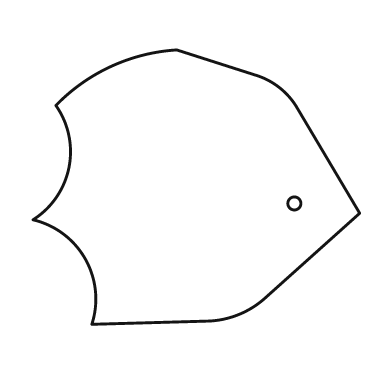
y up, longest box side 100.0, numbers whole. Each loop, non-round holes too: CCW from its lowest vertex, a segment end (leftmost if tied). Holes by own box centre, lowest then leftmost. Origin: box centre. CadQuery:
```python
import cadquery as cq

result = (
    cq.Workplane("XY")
    .moveTo(-32.0, -42.0)
    .lineTo(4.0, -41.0)
    .threePointArc((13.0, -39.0), (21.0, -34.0))
    .lineTo(50.0, -8.0)
    .lineTo(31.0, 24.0)
    .threePointArc((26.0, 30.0), (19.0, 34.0))
    .lineTo(-6.0, 42.0)
    .threePointArc((-26.0, 37.0), (-43.0, 25.0))
    .threePointArc((-39.0, 6.0), (-50.0, -10.0))
    .threePointArc((-34.0, -22.0), (-32.0, -42.0))
    .close()
    .moveTo(30.0, -5.0)
    .circle(2.0)
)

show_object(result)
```